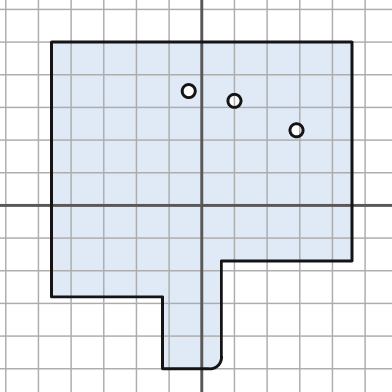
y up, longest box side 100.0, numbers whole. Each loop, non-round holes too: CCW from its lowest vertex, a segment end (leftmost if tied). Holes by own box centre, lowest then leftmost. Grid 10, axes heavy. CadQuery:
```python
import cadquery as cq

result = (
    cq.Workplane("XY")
    .moveTo(-12.0, -50.0)
    .lineTo(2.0, -50.0)
    .threePointArc((5.0, -49.0), (6.0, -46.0))
    .lineTo(6.0, -17.0)
    .lineTo(46.0, -17.0)
    .lineTo(46.0, 50.0)
    .lineTo(-46.0, 50.0)
    .lineTo(-46.0, -28.0)
    .lineTo(-12.0, -28.0)
    .close()
    .moveTo(29.0, 23.0)
    .circle(2.0)
    .moveTo(10.0, 32.0)
    .circle(2.0)
    .moveTo(-4.0, 35.0)
    .circle(2.0)
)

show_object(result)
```